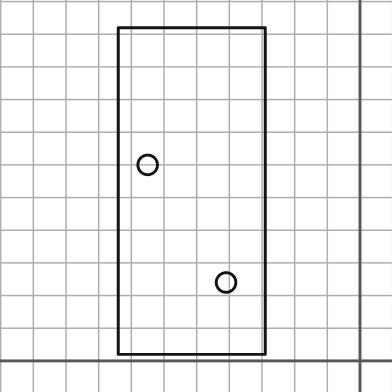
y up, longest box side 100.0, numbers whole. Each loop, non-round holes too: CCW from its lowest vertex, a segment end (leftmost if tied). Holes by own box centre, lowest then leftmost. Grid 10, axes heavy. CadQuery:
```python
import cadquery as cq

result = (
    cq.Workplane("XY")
    .moveTo(-74.0, 2.0)
    .lineTo(-29.0, 2.0)
    .lineTo(-29.0, 102.0)
    .lineTo(-74.0, 102.0)
    .close()
    .moveTo(-41.0, 24.0)
    .circle(3.0)
    .moveTo(-65.0, 60.0)
    .circle(3.0)
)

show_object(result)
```